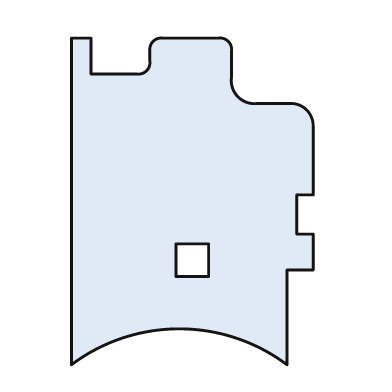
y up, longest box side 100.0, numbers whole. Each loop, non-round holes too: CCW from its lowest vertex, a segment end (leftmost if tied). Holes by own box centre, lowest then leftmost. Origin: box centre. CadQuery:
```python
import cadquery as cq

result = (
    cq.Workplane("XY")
    .moveTo(-37.0, -50.0)
    .threePointArc((-4.0, -39.0), (29.0, -50.0))
    .lineTo(29.0, -21.0)
    .lineTo(37.0, -21.0)
    .lineTo(37.0, -10.0)
    .lineTo(32.0, -10.0)
    .lineTo(32.0, 2.0)
    .lineTo(37.0, 2.0)
    .lineTo(37.0, 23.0)
    .threePointArc((35.0, 28.0), (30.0, 30.0))
    .lineTo(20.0, 30.0)
    .threePointArc((14.0, 32.0), (12.0, 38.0))
    .lineTo(12.0, 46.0)
    .threePointArc((11.0, 49.0), (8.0, 50.0))
    .lineTo(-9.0, 50.0)
    .threePointArc((-12.0, 49.0), (-13.0, 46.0))
    .lineTo(-13.0, 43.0)
    .threePointArc((-14.0, 40.0), (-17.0, 39.0))
    .lineTo(-31.0, 39.0)
    .lineTo(-31.0, 50.0)
    .lineTo(-37.0, 50.0)
    .close()
    .moveTo(-5.0, -23.0)
    .lineTo(5.0, -23.0)
    .lineTo(5.0, -13.0)
    .lineTo(-5.0, -13.0)
    .close()
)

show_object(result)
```